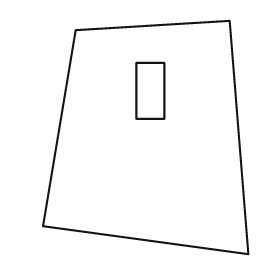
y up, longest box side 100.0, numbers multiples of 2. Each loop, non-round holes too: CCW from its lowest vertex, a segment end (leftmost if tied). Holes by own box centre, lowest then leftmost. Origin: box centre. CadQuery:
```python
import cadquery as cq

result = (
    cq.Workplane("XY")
    .moveTo(44.0, -50.0)
    .lineTo(36.0, 50.0)
    .lineTo(-30.0, 46.0)
    .lineTo(-44.0, -38.0)
    .close()
    .moveTo(-4.0, 8.0)
    .lineTo(8.0, 8.0)
    .lineTo(8.0, 32.0)
    .lineTo(-4.0, 32.0)
    .close()
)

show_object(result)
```